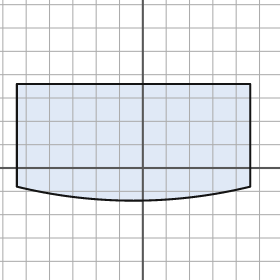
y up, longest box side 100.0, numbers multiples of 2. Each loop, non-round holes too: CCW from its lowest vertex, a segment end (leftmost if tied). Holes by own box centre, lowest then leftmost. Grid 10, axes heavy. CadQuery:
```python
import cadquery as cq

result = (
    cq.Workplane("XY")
    .moveTo(-54.0, -8.0)
    .threePointArc((-4.0, -14.0), (46.0, -8.0))
    .lineTo(46.0, 36.0)
    .lineTo(-54.0, 36.0)
    .close()
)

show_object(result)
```